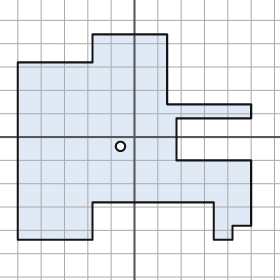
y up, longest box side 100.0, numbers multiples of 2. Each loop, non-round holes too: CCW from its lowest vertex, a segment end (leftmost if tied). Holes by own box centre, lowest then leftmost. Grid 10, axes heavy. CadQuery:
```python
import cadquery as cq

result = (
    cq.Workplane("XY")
    .moveTo(-50.0, -44.0)
    .lineTo(-18.0, -44.0)
    .lineTo(-18.0, -28.0)
    .lineTo(34.0, -28.0)
    .lineTo(34.0, -44.0)
    .lineTo(42.0, -44.0)
    .lineTo(42.0, -38.0)
    .lineTo(50.0, -38.0)
    .lineTo(50.0, -10.0)
    .lineTo(18.0, -10.0)
    .lineTo(18.0, 8.0)
    .lineTo(50.0, 8.0)
    .lineTo(50.0, 14.0)
    .lineTo(14.0, 14.0)
    .lineTo(14.0, 44.0)
    .lineTo(-18.0, 44.0)
    .lineTo(-18.0, 32.0)
    .lineTo(-50.0, 32.0)
    .close()
    .moveTo(-6.0, -4.0)
    .circle(2.0)
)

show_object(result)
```